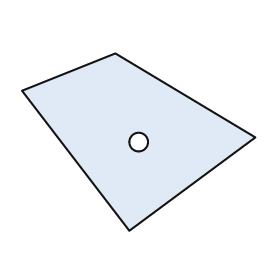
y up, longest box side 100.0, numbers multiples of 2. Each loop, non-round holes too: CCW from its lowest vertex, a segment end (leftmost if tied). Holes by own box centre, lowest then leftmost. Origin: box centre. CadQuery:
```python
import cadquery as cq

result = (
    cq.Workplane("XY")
    .moveTo(-4.0, -38.0)
    .lineTo(50.0, 2.0)
    .lineTo(-10.0, 38.0)
    .lineTo(-50.0, 22.0)
    .close()
    .moveTo(0.0, 0.0)
    .circle(4.0)
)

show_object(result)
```